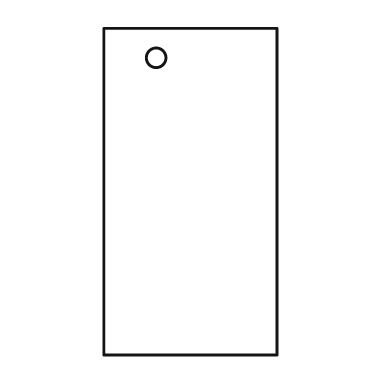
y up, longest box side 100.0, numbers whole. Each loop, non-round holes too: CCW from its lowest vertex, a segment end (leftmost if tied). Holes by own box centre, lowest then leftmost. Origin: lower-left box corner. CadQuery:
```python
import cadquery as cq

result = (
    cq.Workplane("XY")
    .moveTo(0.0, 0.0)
    .lineTo(53.0, 0.0)
    .lineTo(53.0, 100.0)
    .lineTo(0.0, 100.0)
    .close()
    .moveTo(16.0, 91.0)
    .circle(3.0)
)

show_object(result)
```